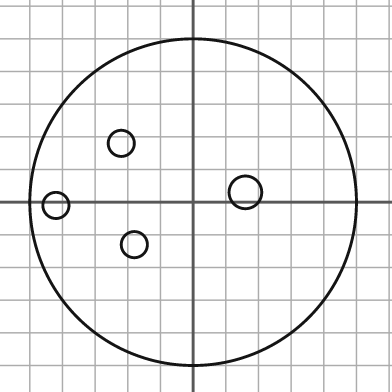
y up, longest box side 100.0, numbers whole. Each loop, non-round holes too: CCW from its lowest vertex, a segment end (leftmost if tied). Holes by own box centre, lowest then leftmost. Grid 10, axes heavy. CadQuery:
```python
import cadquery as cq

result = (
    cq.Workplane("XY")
    .moveTo(0.0, 0.0)
    .circle(50.0)
    .moveTo(-18.0, -13.0)
    .circle(4.0)
    .moveTo(-42.0, -1.0)
    .circle(4.0)
    .moveTo(16.0, 3.0)
    .circle(5.0)
    .moveTo(-22.0, 18.0)
    .circle(4.0)
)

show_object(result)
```